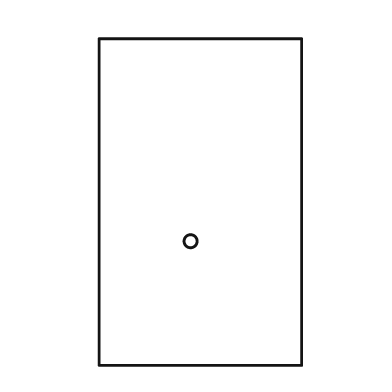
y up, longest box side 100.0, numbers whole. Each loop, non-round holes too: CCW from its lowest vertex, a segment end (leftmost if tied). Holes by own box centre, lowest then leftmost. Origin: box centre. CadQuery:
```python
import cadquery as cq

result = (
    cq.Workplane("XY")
    .moveTo(-31.0, -50.0)
    .lineTo(31.0, -50.0)
    .lineTo(31.0, 50.0)
    .lineTo(-31.0, 50.0)
    .close()
    .moveTo(-3.0, -12.0)
    .circle(2.0)
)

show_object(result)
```